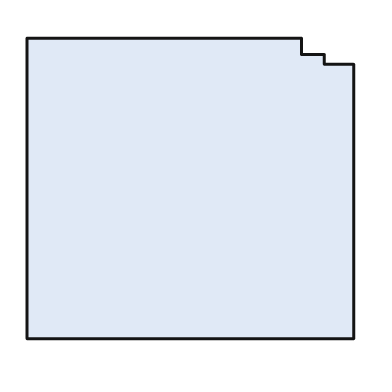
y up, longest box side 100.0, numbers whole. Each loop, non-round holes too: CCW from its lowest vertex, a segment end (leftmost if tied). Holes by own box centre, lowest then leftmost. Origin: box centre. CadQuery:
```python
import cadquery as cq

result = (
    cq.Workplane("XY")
    .moveTo(-50.0, -46.0)
    .lineTo(50.0, -46.0)
    .lineTo(50.0, 38.0)
    .lineTo(41.0, 38.0)
    .lineTo(41.0, 41.0)
    .lineTo(34.0, 41.0)
    .lineTo(34.0, 46.0)
    .lineTo(-50.0, 46.0)
    .close()
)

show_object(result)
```